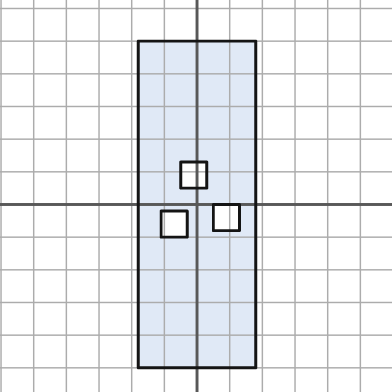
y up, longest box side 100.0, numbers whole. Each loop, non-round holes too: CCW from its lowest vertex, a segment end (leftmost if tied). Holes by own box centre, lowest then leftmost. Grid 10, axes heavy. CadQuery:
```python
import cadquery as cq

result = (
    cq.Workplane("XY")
    .moveTo(-18.0, -50.0)
    .lineTo(18.0, -50.0)
    .lineTo(18.0, 50.0)
    .lineTo(-18.0, 50.0)
    .close()
    .moveTo(-11.0, -10.0)
    .lineTo(-3.0, -10.0)
    .lineTo(-3.0, -2.0)
    .lineTo(-11.0, -2.0)
    .close()
    .moveTo(5.0, -8.0)
    .lineTo(13.0, -8.0)
    .lineTo(13.0, 0.0)
    .lineTo(5.0, 0.0)
    .close()
    .moveTo(-5.0, 5.0)
    .lineTo(3.0, 5.0)
    .lineTo(3.0, 13.0)
    .lineTo(-5.0, 13.0)
    .close()
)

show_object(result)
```